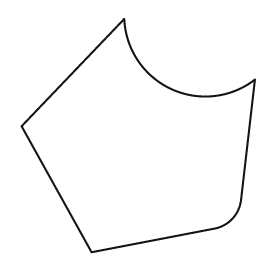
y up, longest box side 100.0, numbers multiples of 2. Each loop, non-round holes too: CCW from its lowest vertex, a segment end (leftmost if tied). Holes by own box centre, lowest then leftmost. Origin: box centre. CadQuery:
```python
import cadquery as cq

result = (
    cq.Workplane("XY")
    .moveTo(-20.0, -50.0)
    .lineTo(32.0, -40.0)
    .threePointArc((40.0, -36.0), (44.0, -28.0))
    .lineTo(50.0, 24.0)
    .threePointArc((14.0, 20.0), (-6.0, 50.0))
    .lineTo(-50.0, 4.0)
    .close()
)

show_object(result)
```